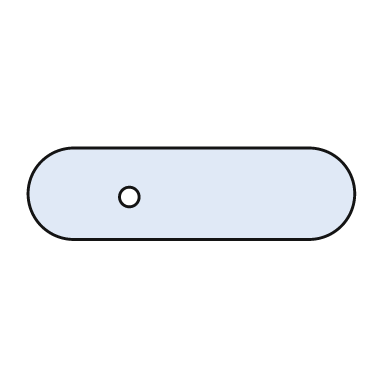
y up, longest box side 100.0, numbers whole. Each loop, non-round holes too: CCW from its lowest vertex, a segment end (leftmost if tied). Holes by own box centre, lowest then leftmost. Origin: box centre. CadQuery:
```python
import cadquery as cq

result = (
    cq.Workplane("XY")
    .moveTo(-36.0, -14.0)
    .lineTo(36.0, -14.0)
    .threePointArc((50.0, 0.0), (36.0, 14.0))
    .lineTo(-36.0, 14.0)
    .threePointArc((-50.0, 0.0), (-36.0, -14.0))
    .close()
    .moveTo(-19.0, -1.0)
    .circle(3.0)
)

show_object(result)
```